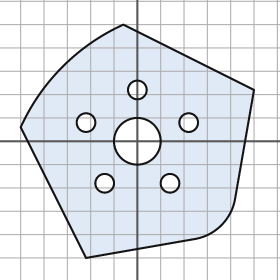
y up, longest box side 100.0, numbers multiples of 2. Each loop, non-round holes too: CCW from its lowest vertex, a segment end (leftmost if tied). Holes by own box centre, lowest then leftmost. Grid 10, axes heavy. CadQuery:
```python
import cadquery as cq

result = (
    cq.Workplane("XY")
    .moveTo(-22.0, -50.0)
    .lineTo(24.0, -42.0)
    .threePointArc((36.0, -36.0), (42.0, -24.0))
    .lineTo(50.0, 22.0)
    .lineTo(-6.0, 50.0)
    .threePointArc((-32.0, 32.0), (-50.0, 6.0))
    .close()
    .moveTo(-14.0, -18.0)
    .circle(4.0)
    .moveTo(14.0, -18.0)
    .circle(4.0)
    .moveTo(0.0, 0.0)
    .circle(10.0)
    .moveTo(-22.0, 8.0)
    .circle(4.0)
    .moveTo(22.0, 8.0)
    .circle(4.0)
    .moveTo(0.0, 22.0)
    .circle(4.0)
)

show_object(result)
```